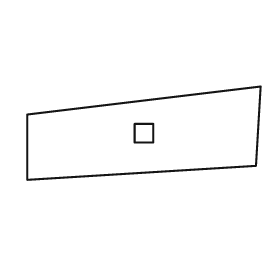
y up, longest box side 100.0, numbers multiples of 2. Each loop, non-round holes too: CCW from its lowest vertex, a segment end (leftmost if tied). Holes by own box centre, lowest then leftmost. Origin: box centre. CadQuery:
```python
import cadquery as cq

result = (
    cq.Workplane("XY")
    .moveTo(-50.0, -20.0)
    .lineTo(48.0, -14.0)
    .lineTo(50.0, 20.0)
    .lineTo(-50.0, 8.0)
    .close()
    .moveTo(-4.0, -4.0)
    .lineTo(4.0, -4.0)
    .lineTo(4.0, 4.0)
    .lineTo(-4.0, 4.0)
    .close()
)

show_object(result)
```